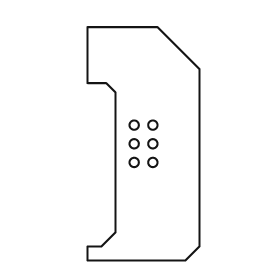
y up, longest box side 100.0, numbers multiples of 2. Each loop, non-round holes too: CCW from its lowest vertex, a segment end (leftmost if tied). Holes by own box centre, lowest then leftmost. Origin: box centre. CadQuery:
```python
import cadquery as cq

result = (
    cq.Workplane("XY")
    .moveTo(-24.0, -50.0)
    .lineTo(18.0, -50.0)
    .lineTo(24.0, -44.0)
    .lineTo(24.0, 32.0)
    .lineTo(6.0, 50.0)
    .lineTo(-24.0, 50.0)
    .lineTo(-24.0, 26.0)
    .lineTo(-16.0, 26.0)
    .lineTo(-12.0, 22.0)
    .lineTo(-12.0, -38.0)
    .lineTo(-18.0, -44.0)
    .lineTo(-24.0, -44.0)
    .close()
    .moveTo(-4.0, -8.0)
    .circle(2.0)
    .moveTo(4.0, -8.0)
    .circle(2.0)
    .moveTo(-4.0, 0.0)
    .circle(2.0)
    .moveTo(4.0, 0.0)
    .circle(2.0)
    .moveTo(-4.0, 8.0)
    .circle(2.0)
    .moveTo(4.0, 8.0)
    .circle(2.0)
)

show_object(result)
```